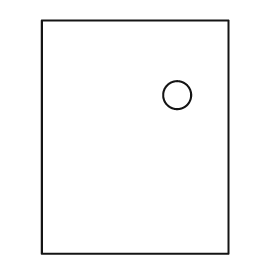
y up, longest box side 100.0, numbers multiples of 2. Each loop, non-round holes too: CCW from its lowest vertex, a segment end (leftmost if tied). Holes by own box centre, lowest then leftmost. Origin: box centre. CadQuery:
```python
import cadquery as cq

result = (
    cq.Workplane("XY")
    .moveTo(-40.0, -50.0)
    .lineTo(40.0, -50.0)
    .lineTo(40.0, 50.0)
    .lineTo(-40.0, 50.0)
    .close()
    .moveTo(18.0, 18.0)
    .circle(6.0)
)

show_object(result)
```